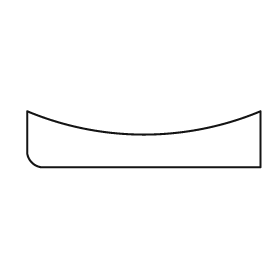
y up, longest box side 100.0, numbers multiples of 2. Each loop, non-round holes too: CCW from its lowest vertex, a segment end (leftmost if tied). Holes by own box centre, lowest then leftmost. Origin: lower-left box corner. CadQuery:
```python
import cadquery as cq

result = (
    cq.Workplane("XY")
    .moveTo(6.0, 0.0)
    .lineTo(100.0, 0.0)
    .lineTo(100.0, 24.0)
    .threePointArc((50.0, 14.0), (0.0, 24.0))
    .lineTo(0.0, 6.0)
    .threePointArc((2.0, 2.0), (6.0, 0.0))
    .close()
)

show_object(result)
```